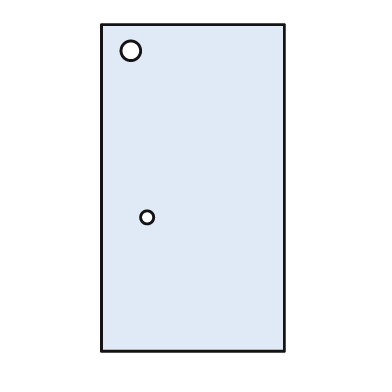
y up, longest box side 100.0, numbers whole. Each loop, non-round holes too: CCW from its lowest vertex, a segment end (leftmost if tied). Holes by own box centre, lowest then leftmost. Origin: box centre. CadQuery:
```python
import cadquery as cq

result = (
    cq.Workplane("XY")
    .moveTo(-28.0, -50.0)
    .lineTo(28.0, -50.0)
    .lineTo(28.0, 50.0)
    .lineTo(-28.0, 50.0)
    .close()
    .moveTo(-14.0, -9.0)
    .circle(2.0)
    .moveTo(-19.0, 42.0)
    .circle(3.0)
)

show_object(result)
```